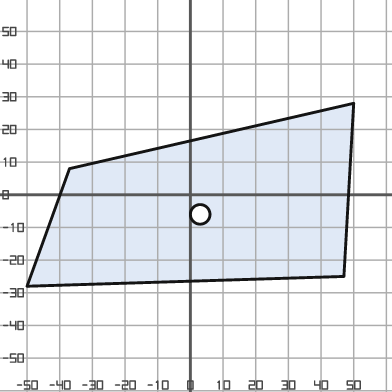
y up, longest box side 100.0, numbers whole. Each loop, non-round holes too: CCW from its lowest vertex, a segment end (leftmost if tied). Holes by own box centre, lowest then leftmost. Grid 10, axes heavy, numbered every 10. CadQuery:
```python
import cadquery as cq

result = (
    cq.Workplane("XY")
    .moveTo(-50.0, -28.0)
    .lineTo(47.0, -25.0)
    .lineTo(50.0, 28.0)
    .lineTo(-37.0, 8.0)
    .close()
    .moveTo(3.0, -6.0)
    .circle(3.0)
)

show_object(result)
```